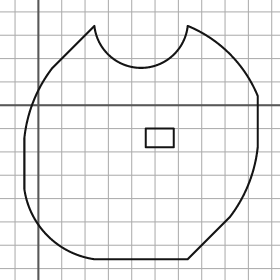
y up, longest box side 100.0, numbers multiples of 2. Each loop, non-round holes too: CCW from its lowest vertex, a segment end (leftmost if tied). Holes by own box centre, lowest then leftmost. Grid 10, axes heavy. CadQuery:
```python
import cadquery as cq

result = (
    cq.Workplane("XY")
    .moveTo(24.0, -66.0)
    .lineTo(64.0, -66.0)
    .lineTo(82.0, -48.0)
    .threePointArc((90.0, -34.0), (94.0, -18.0))
    .lineTo(94.0, 4.0)
    .threePointArc((82.0, 22.0), (64.0, 34.0))
    .threePointArc((44.0, 16.0), (24.0, 34.0))
    .lineTo(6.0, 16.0)
    .threePointArc((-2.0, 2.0), (-6.0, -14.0))
    .lineTo(-6.0, -36.0)
    .threePointArc((4.0, -56.0), (24.0, -66.0))
    .close()
    .moveTo(46.0, -18.0)
    .lineTo(58.0, -18.0)
    .lineTo(58.0, -10.0)
    .lineTo(46.0, -10.0)
    .close()
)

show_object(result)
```